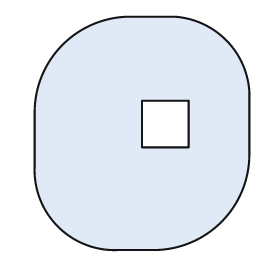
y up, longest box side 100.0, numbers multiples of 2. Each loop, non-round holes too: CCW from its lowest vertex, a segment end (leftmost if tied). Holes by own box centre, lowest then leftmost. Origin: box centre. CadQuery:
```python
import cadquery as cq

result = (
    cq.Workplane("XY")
    .moveTo(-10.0, -50.0)
    .lineTo(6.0, -50.0)
    .threePointArc((34.0, -38.0), (46.0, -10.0))
    .lineTo(46.0, 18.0)
    .threePointArc((36.0, 40.0), (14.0, 50.0))
    .lineTo(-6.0, 50.0)
    .threePointArc((-34.0, 38.0), (-46.0, 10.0))
    .lineTo(-46.0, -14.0)
    .threePointArc((-36.0, -40.0), (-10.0, -50.0))
    .close()
    .moveTo(0.0, -6.0)
    .lineTo(20.0, -6.0)
    .lineTo(20.0, 14.0)
    .lineTo(0.0, 14.0)
    .close()
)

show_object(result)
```